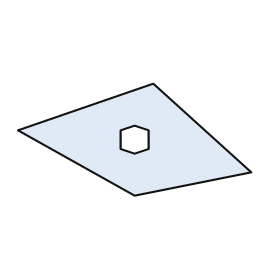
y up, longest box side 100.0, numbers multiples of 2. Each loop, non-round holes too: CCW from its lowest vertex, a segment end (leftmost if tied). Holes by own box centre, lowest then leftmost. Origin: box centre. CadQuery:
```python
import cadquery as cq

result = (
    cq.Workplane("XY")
    .moveTo(0.0, -24.0)
    .lineTo(50.0, -14.0)
    .lineTo(8.0, 24.0)
    .lineTo(-50.0, 4.0)
    .close()
    .moveTo(0.0, -6.0)
    .lineTo(6.0, -4.0)
    .lineTo(6.0, 4.0)
    .lineTo(0.0, 6.0)
    .lineTo(-6.0, 4.0)
    .lineTo(-6.0, -4.0)
    .close()
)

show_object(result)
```